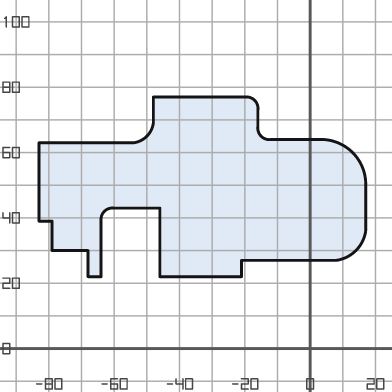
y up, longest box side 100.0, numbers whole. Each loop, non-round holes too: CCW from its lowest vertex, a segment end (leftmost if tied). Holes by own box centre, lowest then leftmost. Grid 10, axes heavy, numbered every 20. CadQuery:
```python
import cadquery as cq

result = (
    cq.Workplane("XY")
    .moveTo(-68.0, 22.0)
    .lineTo(-64.0, 22.0)
    .lineTo(-64.0, 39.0)
    .threePointArc((-63.0, 42.0), (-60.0, 43.0))
    .lineTo(-46.0, 43.0)
    .lineTo(-46.0, 22.0)
    .lineTo(-21.0, 22.0)
    .lineTo(-21.0, 27.0)
    .lineTo(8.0, 27.0)
    .threePointArc((14.0, 30.0), (17.0, 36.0))
    .lineTo(17.0, 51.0)
    .threePointArc((13.0, 60.0), (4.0, 64.0))
    .lineTo(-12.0, 64.0)
    .threePointArc((-15.0, 65.0), (-16.0, 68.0))
    .lineTo(-16.0, 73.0)
    .threePointArc((-17.0, 76.0), (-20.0, 77.0))
    .lineTo(-48.0, 77.0)
    .lineTo(-48.0, 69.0)
    .threePointArc((-50.0, 65.0), (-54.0, 63.0))
    .lineTo(-83.0, 63.0)
    .lineTo(-83.0, 39.0)
    .lineTo(-79.0, 39.0)
    .lineTo(-79.0, 30.0)
    .lineTo(-68.0, 30.0)
    .close()
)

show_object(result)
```